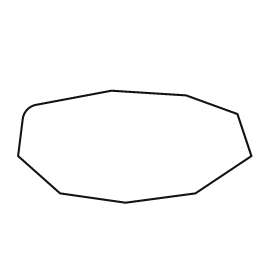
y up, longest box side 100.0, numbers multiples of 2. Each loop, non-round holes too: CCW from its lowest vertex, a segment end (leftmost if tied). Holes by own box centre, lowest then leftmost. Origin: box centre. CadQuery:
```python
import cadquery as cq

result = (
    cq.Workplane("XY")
    .moveTo(-4.0, -24.0)
    .lineTo(26.0, -20.0)
    .lineTo(50.0, -4.0)
    .lineTo(44.0, 14.0)
    .lineTo(22.0, 22.0)
    .lineTo(-10.0, 24.0)
    .lineTo(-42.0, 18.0)
    .threePointArc((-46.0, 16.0), (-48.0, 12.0))
    .lineTo(-50.0, -4.0)
    .lineTo(-32.0, -20.0)
    .close()
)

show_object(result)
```